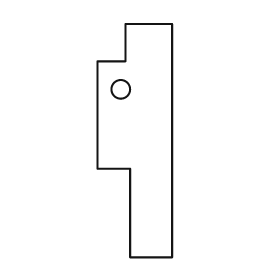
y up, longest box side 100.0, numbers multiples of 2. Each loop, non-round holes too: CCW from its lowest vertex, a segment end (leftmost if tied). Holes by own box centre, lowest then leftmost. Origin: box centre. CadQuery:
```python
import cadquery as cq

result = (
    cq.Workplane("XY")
    .moveTo(-2.0, -50.0)
    .lineTo(16.0, -50.0)
    .lineTo(16.0, 50.0)
    .lineTo(-4.0, 50.0)
    .lineTo(-4.0, 34.0)
    .lineTo(-16.0, 34.0)
    .lineTo(-16.0, -12.0)
    .lineTo(-2.0, -12.0)
    .close()
    .moveTo(-6.0, 22.0)
    .circle(4.0)
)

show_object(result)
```